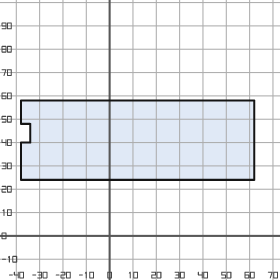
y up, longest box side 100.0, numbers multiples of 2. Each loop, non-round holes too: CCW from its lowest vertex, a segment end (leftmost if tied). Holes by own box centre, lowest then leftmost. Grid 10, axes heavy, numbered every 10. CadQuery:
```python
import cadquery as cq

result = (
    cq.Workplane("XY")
    .moveTo(-38.0, 24.0)
    .lineTo(62.0, 24.0)
    .lineTo(62.0, 58.0)
    .lineTo(-38.0, 58.0)
    .lineTo(-38.0, 48.0)
    .lineTo(-34.0, 48.0)
    .lineTo(-34.0, 40.0)
    .lineTo(-38.0, 40.0)
    .close()
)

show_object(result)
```